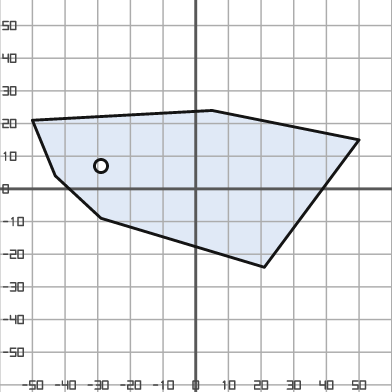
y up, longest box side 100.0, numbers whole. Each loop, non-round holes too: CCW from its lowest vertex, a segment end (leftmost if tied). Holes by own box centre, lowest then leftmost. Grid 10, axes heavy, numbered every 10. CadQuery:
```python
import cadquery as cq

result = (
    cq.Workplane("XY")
    .moveTo(21.0, -24.0)
    .lineTo(50.0, 15.0)
    .lineTo(5.0, 24.0)
    .lineTo(-50.0, 21.0)
    .lineTo(-43.0, 4.0)
    .lineTo(-29.0, -9.0)
    .close()
    .moveTo(-29.0, 7.0)
    .circle(2.0)
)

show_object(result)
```